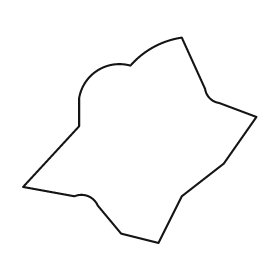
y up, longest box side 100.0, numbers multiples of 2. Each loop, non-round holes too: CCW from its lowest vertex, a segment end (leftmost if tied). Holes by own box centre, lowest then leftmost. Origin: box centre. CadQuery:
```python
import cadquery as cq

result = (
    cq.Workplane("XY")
    .moveTo(8.0, -44.0)
    .lineTo(18.0, -24.0)
    .lineTo(36.0, -10.0)
    .lineTo(50.0, 10.0)
    .lineTo(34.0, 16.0)
    .threePointArc((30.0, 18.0), (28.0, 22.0))
    .lineTo(18.0, 44.0)
    .threePointArc((6.0, 40.0), (-4.0, 32.0))
    .threePointArc((-18.0, 30.0), (-26.0, 18.0))
    .lineTo(-26.0, 6.0)
    .lineTo(-50.0, -20.0)
    .lineTo(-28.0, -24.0)
    .threePointArc((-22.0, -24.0), (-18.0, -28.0))
    .lineTo(-8.0, -40.0)
    .close()
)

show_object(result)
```